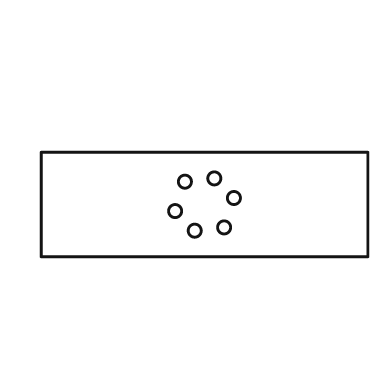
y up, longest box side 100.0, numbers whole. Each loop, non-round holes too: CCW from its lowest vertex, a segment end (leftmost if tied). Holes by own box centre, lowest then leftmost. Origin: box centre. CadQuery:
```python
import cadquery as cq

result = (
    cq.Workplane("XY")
    .moveTo(-50.0, -16.0)
    .lineTo(50.0, -16.0)
    .lineTo(50.0, 16.0)
    .lineTo(-50.0, 16.0)
    .close()
    .moveTo(-3.0, -8.0)
    .circle(2.0)
    .moveTo(6.0, -7.0)
    .circle(2.0)
    .moveTo(-9.0, -2.0)
    .circle(2.0)
    .moveTo(9.0, 2.0)
    .circle(2.0)
    .moveTo(-6.0, 7.0)
    .circle(2.0)
    .moveTo(3.0, 8.0)
    .circle(2.0)
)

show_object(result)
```